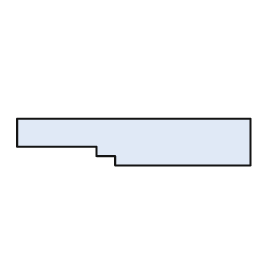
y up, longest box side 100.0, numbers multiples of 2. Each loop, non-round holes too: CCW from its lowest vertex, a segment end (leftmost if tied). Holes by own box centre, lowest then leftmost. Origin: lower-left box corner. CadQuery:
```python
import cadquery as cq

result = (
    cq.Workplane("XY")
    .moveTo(42.0, 0.0)
    .lineTo(100.0, 0.0)
    .lineTo(100.0, 20.0)
    .lineTo(0.0, 20.0)
    .lineTo(0.0, 8.0)
    .lineTo(34.0, 8.0)
    .lineTo(34.0, 4.0)
    .lineTo(42.0, 4.0)
    .close()
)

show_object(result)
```